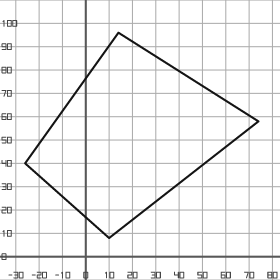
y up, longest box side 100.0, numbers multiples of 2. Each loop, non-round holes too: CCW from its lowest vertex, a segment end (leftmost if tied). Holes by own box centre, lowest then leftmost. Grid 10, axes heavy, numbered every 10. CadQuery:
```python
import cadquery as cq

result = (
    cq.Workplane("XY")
    .moveTo(10.0, 8.0)
    .lineTo(74.0, 58.0)
    .lineTo(14.0, 96.0)
    .lineTo(-26.0, 40.0)
    .close()
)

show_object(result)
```